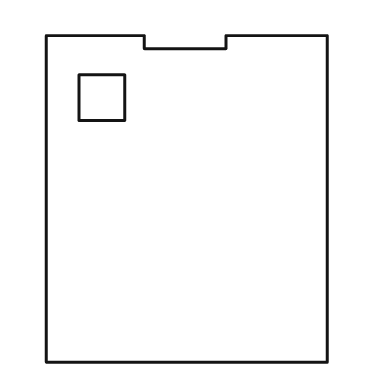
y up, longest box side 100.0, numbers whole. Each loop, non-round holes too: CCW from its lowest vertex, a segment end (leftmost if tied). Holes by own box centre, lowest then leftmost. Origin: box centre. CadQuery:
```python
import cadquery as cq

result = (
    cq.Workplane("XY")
    .moveTo(-43.0, -50.0)
    .lineTo(43.0, -50.0)
    .lineTo(43.0, 50.0)
    .lineTo(12.0, 50.0)
    .lineTo(12.0, 46.0)
    .lineTo(-13.0, 46.0)
    .lineTo(-13.0, 50.0)
    .lineTo(-43.0, 50.0)
    .close()
    .moveTo(-33.0, 24.0)
    .lineTo(-19.0, 24.0)
    .lineTo(-19.0, 38.0)
    .lineTo(-33.0, 38.0)
    .close()
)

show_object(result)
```